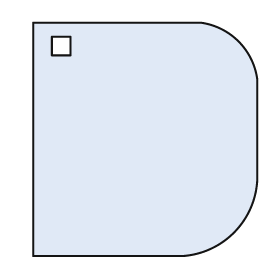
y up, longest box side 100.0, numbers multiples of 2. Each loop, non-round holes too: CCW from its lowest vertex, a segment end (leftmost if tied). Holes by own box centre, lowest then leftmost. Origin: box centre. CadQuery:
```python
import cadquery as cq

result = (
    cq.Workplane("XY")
    .moveTo(-48.0, -50.0)
    .lineTo(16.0, -50.0)
    .threePointArc((38.0, -40.0), (48.0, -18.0))
    .lineTo(48.0, 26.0)
    .threePointArc((40.0, 42.0), (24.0, 50.0))
    .lineTo(-48.0, 50.0)
    .close()
    .moveTo(-40.0, 36.0)
    .lineTo(-32.0, 36.0)
    .lineTo(-32.0, 44.0)
    .lineTo(-40.0, 44.0)
    .close()
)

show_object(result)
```